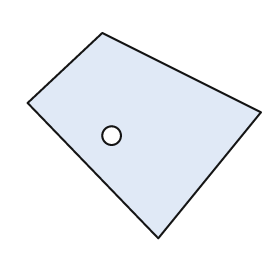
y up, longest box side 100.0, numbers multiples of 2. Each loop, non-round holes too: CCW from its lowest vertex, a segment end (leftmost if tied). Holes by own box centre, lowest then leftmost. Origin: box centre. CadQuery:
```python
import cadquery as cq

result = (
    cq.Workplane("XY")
    .moveTo(6.0, -44.0)
    .lineTo(50.0, 10.0)
    .lineTo(-18.0, 44.0)
    .lineTo(-50.0, 14.0)
    .close()
    .moveTo(-14.0, 0.0)
    .circle(4.0)
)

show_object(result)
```